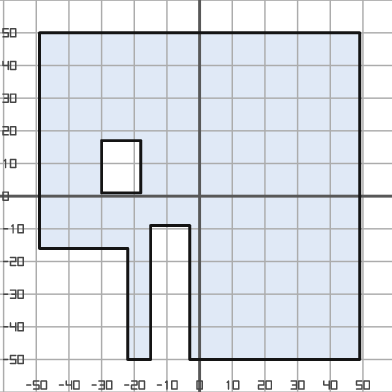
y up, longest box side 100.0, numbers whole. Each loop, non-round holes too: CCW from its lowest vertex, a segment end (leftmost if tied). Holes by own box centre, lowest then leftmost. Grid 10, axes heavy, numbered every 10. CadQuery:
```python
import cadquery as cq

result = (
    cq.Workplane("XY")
    .moveTo(-22.0, -50.0)
    .lineTo(-15.0, -50.0)
    .lineTo(-15.0, -9.0)
    .lineTo(-3.0, -9.0)
    .lineTo(-3.0, -50.0)
    .lineTo(49.0, -50.0)
    .lineTo(49.0, 50.0)
    .lineTo(-49.0, 50.0)
    .lineTo(-49.0, -16.0)
    .lineTo(-22.0, -16.0)
    .close()
    .moveTo(-30.0, 1.0)
    .lineTo(-18.0, 1.0)
    .lineTo(-18.0, 17.0)
    .lineTo(-30.0, 17.0)
    .close()
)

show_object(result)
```